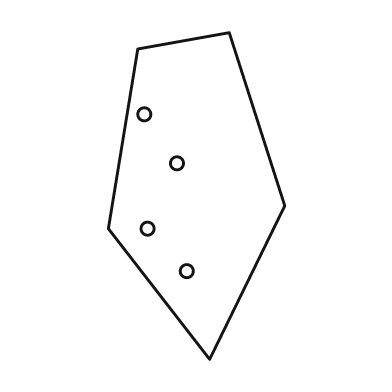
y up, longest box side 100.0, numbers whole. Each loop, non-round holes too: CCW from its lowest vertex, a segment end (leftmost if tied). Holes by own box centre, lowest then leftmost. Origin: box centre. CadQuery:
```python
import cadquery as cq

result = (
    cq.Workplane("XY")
    .moveTo(4.0, -50.0)
    .lineTo(27.0, -3.0)
    .lineTo(10.0, 50.0)
    .lineTo(-18.0, 45.0)
    .lineTo(-27.0, -10.0)
    .close()
    .moveTo(-3.0, -23.0)
    .circle(2.0)
    .moveTo(-15.0, -10.0)
    .circle(2.0)
    .moveTo(-6.0, 10.0)
    .circle(2.0)
    .moveTo(-16.0, 25.0)
    .circle(2.0)
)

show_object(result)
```